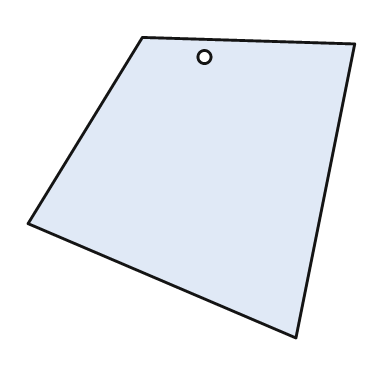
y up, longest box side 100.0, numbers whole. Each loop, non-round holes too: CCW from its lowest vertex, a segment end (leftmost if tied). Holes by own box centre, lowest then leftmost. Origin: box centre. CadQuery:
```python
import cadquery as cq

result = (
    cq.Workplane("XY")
    .moveTo(32.0, -46.0)
    .lineTo(50.0, 44.0)
    .lineTo(-15.0, 46.0)
    .lineTo(-50.0, -11.0)
    .close()
    .moveTo(4.0, 40.0)
    .circle(2.0)
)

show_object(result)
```